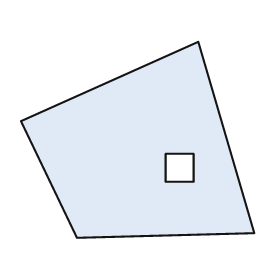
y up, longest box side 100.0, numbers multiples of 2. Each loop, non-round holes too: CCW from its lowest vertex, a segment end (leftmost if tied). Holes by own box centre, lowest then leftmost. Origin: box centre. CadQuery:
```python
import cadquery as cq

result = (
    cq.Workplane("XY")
    .moveTo(-26.0, -42.0)
    .lineTo(50.0, -40.0)
    .lineTo(26.0, 42.0)
    .lineTo(-50.0, 8.0)
    .close()
    .moveTo(12.0, -18.0)
    .lineTo(24.0, -18.0)
    .lineTo(24.0, -6.0)
    .lineTo(12.0, -6.0)
    .close()
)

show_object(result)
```